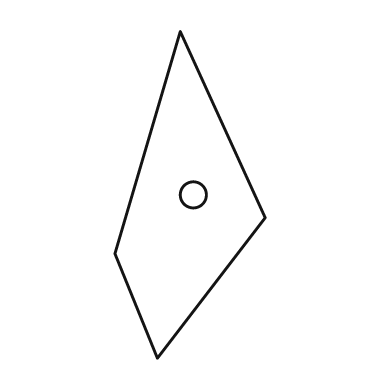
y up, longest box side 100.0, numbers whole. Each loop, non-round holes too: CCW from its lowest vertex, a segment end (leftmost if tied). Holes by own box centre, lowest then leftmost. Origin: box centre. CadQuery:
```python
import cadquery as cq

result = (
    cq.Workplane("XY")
    .moveTo(-10.0, -50.0)
    .lineTo(23.0, -7.0)
    .lineTo(-3.0, 50.0)
    .lineTo(-23.0, -18.0)
    .close()
    .moveTo(1.0, 0.0)
    .circle(4.0)
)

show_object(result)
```